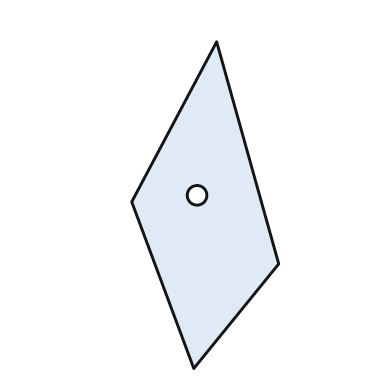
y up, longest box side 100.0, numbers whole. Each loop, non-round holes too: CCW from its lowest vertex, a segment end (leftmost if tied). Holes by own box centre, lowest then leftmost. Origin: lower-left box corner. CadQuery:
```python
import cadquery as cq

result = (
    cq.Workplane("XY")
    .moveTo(19.0, 0.0)
    .lineTo(45.0, 32.0)
    .lineTo(26.0, 100.0)
    .lineTo(0.0, 51.0)
    .close()
    .moveTo(20.0, 53.0)
    .circle(3.0)
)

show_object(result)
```